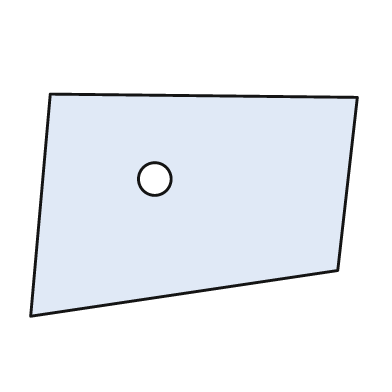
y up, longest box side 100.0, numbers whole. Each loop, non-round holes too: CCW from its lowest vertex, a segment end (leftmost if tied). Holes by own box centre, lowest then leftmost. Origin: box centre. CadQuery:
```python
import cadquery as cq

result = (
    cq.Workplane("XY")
    .moveTo(-50.0, -34.0)
    .lineTo(44.0, -20.0)
    .lineTo(50.0, 33.0)
    .lineTo(-44.0, 34.0)
    .close()
    .moveTo(-12.0, 8.0)
    .circle(5.0)
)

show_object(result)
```